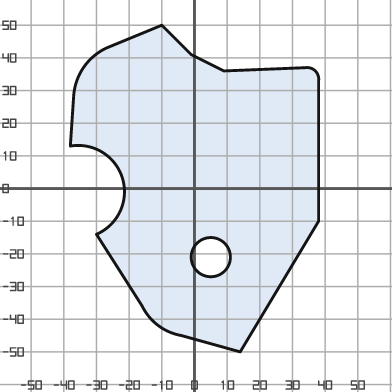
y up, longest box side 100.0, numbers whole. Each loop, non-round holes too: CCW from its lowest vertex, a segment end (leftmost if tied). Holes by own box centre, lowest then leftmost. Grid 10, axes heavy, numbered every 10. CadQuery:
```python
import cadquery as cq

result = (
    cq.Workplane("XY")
    .moveTo(14.0, -50.0)
    .lineTo(38.0, -10.0)
    .lineTo(38.0, 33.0)
    .threePointArc((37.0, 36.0), (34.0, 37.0))
    .lineTo(9.0, 36.0)
    .lineTo(-1.0, 41.0)
    .lineTo(-10.0, 50.0)
    .lineTo(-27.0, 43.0)
    .threePointArc((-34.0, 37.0), (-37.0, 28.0))
    .lineTo(-38.0, 13.0)
    .threePointArc((-22.0, 3.0), (-30.0, -14.0))
    .lineTo(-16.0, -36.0)
    .threePointArc((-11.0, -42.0), (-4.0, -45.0))
    .close()
    .moveTo(5.0, -21.0)
    .circle(6.0)
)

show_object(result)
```